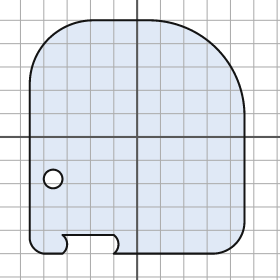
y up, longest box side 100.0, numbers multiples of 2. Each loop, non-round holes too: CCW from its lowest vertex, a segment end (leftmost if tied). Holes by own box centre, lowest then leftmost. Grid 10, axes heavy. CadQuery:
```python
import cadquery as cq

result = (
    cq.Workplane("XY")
    .moveTo(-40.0, -50.0)
    .lineTo(-32.0, -50.0)
    .threePointArc((-30.0, -46.0), (-32.0, -42.0))
    .lineTo(-10.0, -42.0)
    .threePointArc((-8.0, -46.0), (-10.0, -50.0))
    .lineTo(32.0, -50.0)
    .threePointArc((42.0, -46.0), (46.0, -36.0))
    .lineTo(46.0, 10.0)
    .threePointArc((34.0, 38.0), (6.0, 50.0))
    .lineTo(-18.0, 50.0)
    .threePointArc((-38.0, 42.0), (-46.0, 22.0))
    .lineTo(-46.0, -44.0)
    .threePointArc((-44.0, -48.0), (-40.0, -50.0))
    .close()
    .moveTo(-36.0, -18.0)
    .circle(4.0)
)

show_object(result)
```